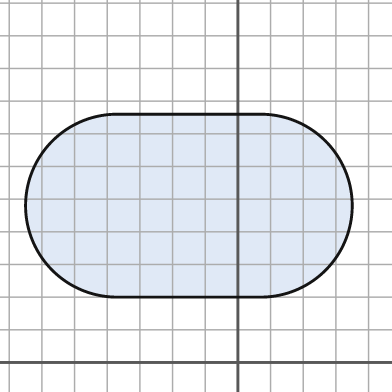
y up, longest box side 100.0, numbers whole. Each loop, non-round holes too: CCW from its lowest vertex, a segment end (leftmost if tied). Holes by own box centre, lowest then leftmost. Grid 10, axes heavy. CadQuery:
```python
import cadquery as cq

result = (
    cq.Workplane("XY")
    .moveTo(-37.0, 20.0)
    .lineTo(7.0, 20.0)
    .threePointArc((35.0, 48.0), (7.0, 76.0))
    .lineTo(-37.0, 76.0)
    .threePointArc((-65.0, 48.0), (-37.0, 20.0))
    .close()
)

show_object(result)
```